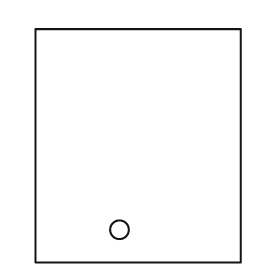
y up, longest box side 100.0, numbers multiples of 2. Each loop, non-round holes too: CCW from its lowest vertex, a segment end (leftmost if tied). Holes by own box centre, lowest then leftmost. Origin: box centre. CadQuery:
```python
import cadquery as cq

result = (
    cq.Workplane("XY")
    .moveTo(-44.0, -50.0)
    .lineTo(44.0, -50.0)
    .lineTo(44.0, 50.0)
    .lineTo(-44.0, 50.0)
    .close()
    .moveTo(-8.0, -36.0)
    .circle(4.0)
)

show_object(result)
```